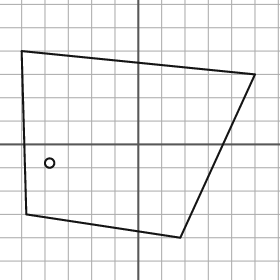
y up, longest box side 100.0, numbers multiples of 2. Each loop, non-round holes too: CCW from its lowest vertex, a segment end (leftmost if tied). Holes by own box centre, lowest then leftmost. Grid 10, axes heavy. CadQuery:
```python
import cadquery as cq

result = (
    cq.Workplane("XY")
    .moveTo(18.0, -40.0)
    .lineTo(50.0, 30.0)
    .lineTo(-50.0, 40.0)
    .lineTo(-48.0, -30.0)
    .close()
    .moveTo(-38.0, -8.0)
    .circle(2.0)
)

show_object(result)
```